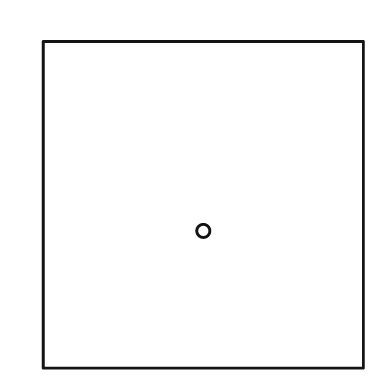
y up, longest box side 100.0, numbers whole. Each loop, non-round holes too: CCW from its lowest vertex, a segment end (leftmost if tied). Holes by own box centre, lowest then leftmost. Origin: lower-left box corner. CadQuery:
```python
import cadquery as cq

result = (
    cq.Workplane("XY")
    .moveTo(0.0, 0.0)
    .lineTo(98.0, 0.0)
    .lineTo(98.0, 100.0)
    .lineTo(0.0, 100.0)
    .close()
    .moveTo(49.0, 42.0)
    .circle(2.0)
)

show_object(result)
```